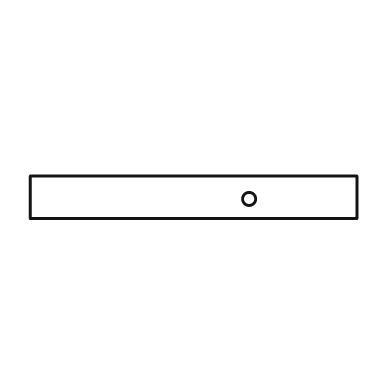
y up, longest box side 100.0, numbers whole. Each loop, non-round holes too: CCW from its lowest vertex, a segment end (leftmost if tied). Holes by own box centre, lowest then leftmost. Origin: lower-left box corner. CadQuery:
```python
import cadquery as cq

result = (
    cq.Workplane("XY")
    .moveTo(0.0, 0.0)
    .lineTo(100.0, 0.0)
    .lineTo(100.0, 13.0)
    .lineTo(0.0, 13.0)
    .close()
    .moveTo(67.0, 6.0)
    .circle(2.0)
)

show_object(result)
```